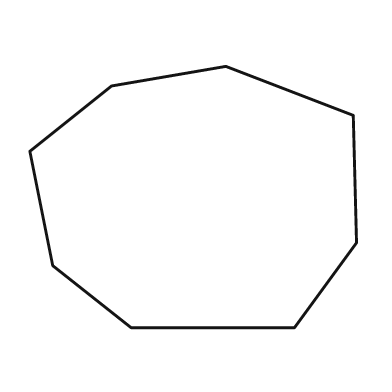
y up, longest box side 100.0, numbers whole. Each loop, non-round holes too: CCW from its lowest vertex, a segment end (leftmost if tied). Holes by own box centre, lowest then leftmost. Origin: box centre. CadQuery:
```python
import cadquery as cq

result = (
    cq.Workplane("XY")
    .moveTo(-19.0, -40.0)
    .lineTo(31.0, -40.0)
    .lineTo(50.0, -14.0)
    .lineTo(49.0, 25.0)
    .lineTo(10.0, 40.0)
    .lineTo(-25.0, 34.0)
    .lineTo(-50.0, 14.0)
    .lineTo(-43.0, -21.0)
    .close()
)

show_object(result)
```